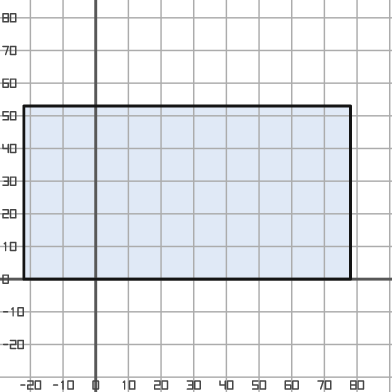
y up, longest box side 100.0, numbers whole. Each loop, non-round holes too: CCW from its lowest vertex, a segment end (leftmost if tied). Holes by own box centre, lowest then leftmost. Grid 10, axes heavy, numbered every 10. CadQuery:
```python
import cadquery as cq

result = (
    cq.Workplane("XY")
    .moveTo(-22.0, 0.0)
    .lineTo(78.0, 0.0)
    .lineTo(78.0, 53.0)
    .lineTo(-22.0, 53.0)
    .close()
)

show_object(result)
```